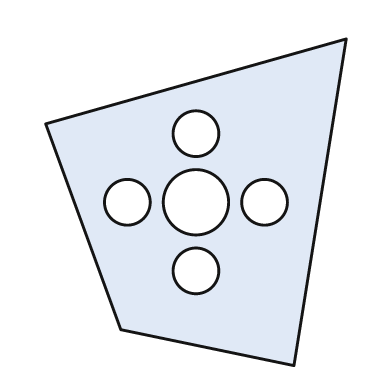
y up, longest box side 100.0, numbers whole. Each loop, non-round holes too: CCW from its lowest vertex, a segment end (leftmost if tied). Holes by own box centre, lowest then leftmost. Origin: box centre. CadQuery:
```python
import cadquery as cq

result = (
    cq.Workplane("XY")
    .moveTo(30.0, -50.0)
    .lineTo(46.0, 50.0)
    .lineTo(-46.0, 24.0)
    .lineTo(-23.0, -39.0)
    .close()
    .moveTo(0.0, -21.0)
    .circle(7.0)
    .moveTo(-21.0, 0.0)
    .circle(7.0)
    .moveTo(0.0, 0.0)
    .circle(10.0)
    .moveTo(21.0, 0.0)
    .circle(7.0)
    .moveTo(0.0, 21.0)
    .circle(7.0)
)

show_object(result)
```